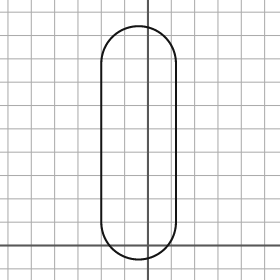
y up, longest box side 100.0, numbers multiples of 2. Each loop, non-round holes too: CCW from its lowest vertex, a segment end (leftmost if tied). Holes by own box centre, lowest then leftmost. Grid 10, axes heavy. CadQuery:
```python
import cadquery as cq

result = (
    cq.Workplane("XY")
    .moveTo(-20.0, 10.0)
    .threePointArc((-4.0, -6.0), (12.0, 10.0))
    .lineTo(12.0, 78.0)
    .threePointArc((-4.0, 94.0), (-20.0, 78.0))
    .close()
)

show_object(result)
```